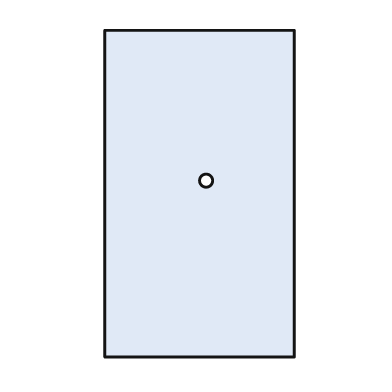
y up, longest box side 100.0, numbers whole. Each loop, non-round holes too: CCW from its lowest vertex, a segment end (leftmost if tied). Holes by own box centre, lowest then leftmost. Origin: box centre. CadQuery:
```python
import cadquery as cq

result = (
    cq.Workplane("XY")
    .moveTo(-29.0, -50.0)
    .lineTo(29.0, -50.0)
    .lineTo(29.0, 50.0)
    .lineTo(-29.0, 50.0)
    .close()
    .moveTo(2.0, 4.0)
    .circle(2.0)
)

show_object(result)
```